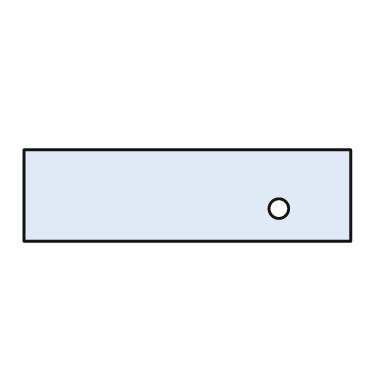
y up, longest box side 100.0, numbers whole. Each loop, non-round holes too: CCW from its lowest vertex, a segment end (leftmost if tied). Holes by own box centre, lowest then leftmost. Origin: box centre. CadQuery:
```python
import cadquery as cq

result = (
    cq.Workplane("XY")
    .moveTo(-50.0, -14.0)
    .lineTo(50.0, -14.0)
    .lineTo(50.0, 14.0)
    .lineTo(-50.0, 14.0)
    .close()
    .moveTo(28.0, -4.0)
    .circle(3.0)
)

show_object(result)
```